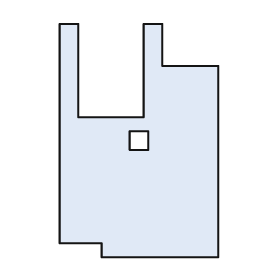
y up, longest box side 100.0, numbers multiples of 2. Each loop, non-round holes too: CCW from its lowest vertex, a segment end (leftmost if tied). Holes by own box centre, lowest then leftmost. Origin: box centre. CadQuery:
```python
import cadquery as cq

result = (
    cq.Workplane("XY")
    .moveTo(-16.0, -50.0)
    .lineTo(34.0, -50.0)
    .lineTo(34.0, 32.0)
    .lineTo(10.0, 32.0)
    .lineTo(10.0, 50.0)
    .lineTo(2.0, 50.0)
    .lineTo(2.0, 10.0)
    .lineTo(-26.0, 10.0)
    .lineTo(-26.0, 50.0)
    .lineTo(-34.0, 50.0)
    .lineTo(-34.0, -44.0)
    .lineTo(-16.0, -44.0)
    .close()
    .moveTo(-4.0, -4.0)
    .lineTo(4.0, -4.0)
    .lineTo(4.0, 4.0)
    .lineTo(-4.0, 4.0)
    .close()
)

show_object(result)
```